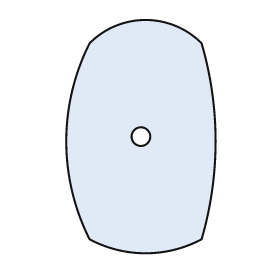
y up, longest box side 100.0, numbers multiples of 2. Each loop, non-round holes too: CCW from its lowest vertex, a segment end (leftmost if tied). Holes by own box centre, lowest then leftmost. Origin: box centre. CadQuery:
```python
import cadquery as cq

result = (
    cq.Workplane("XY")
    .moveTo(-22.0, -44.0)
    .threePointArc((2.0, -50.0), (26.0, -44.0))
    .threePointArc((32.0, -2.0), (26.0, 40.0))
    .threePointArc((2.0, 50.0), (-22.0, 40.0))
    .threePointArc((-32.0, -2.0), (-22.0, -44.0))
    .close()
    .moveTo(0.0, 0.0)
    .circle(4.0)
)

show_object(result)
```